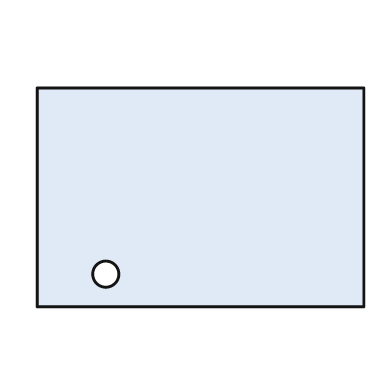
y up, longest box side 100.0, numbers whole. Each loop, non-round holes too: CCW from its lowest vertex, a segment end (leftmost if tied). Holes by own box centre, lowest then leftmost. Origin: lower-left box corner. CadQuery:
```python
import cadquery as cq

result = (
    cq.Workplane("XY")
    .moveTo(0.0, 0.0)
    .lineTo(100.0, 0.0)
    .lineTo(100.0, 67.0)
    .lineTo(0.0, 67.0)
    .close()
    .moveTo(21.0, 10.0)
    .circle(4.0)
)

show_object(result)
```